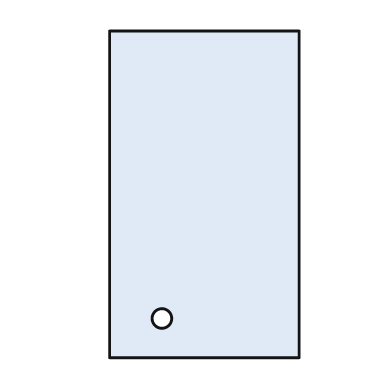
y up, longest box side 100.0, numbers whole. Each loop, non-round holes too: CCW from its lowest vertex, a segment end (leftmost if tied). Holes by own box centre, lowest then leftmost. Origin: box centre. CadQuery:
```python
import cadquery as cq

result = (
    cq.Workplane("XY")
    .moveTo(-29.0, -50.0)
    .lineTo(29.0, -50.0)
    .lineTo(29.0, 50.0)
    .lineTo(-29.0, 50.0)
    .close()
    .moveTo(-13.0, -38.0)
    .circle(3.0)
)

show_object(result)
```